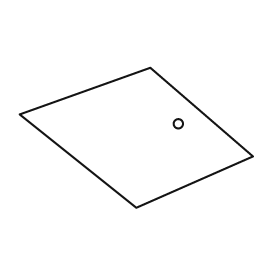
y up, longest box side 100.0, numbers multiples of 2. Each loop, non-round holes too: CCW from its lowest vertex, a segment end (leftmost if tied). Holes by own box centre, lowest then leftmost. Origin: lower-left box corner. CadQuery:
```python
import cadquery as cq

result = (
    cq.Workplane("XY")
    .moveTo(50.0, 0.0)
    .lineTo(100.0, 22.0)
    .lineTo(56.0, 60.0)
    .lineTo(0.0, 40.0)
    .close()
    .moveTo(68.0, 36.0)
    .circle(2.0)
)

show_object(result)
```